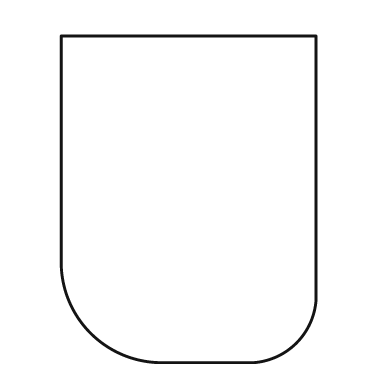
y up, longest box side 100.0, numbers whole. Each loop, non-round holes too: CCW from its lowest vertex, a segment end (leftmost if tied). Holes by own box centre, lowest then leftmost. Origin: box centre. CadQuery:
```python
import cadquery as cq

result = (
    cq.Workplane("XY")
    .moveTo(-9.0, -50.0)
    .lineTo(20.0, -50.0)
    .threePointArc((33.0, -44.0), (39.0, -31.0))
    .lineTo(39.0, 50.0)
    .lineTo(-39.0, 50.0)
    .lineTo(-39.0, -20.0)
    .threePointArc((-30.0, -41.0), (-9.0, -50.0))
    .close()
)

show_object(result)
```